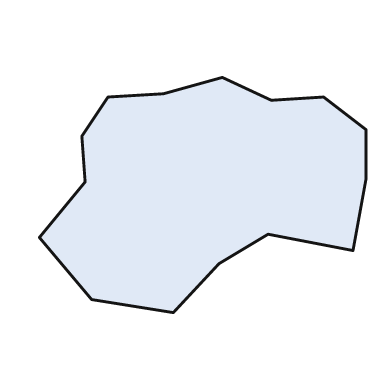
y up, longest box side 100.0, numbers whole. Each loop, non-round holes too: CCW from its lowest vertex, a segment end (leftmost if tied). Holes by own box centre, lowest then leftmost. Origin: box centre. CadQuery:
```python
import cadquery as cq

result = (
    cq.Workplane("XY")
    .moveTo(-9.0, -36.0)
    .lineTo(5.0, -21.0)
    .lineTo(20.0, -12.0)
    .lineTo(46.0, -17.0)
    .lineTo(50.0, 5.0)
    .lineTo(50.0, 20.0)
    .lineTo(37.0, 30.0)
    .lineTo(21.0, 29.0)
    .lineTo(6.0, 36.0)
    .lineTo(-12.0, 31.0)
    .lineTo(-29.0, 30.0)
    .lineTo(-37.0, 18.0)
    .lineTo(-36.0, 4.0)
    .lineTo(-50.0, -13.0)
    .lineTo(-34.0, -32.0)
    .close()
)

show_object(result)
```